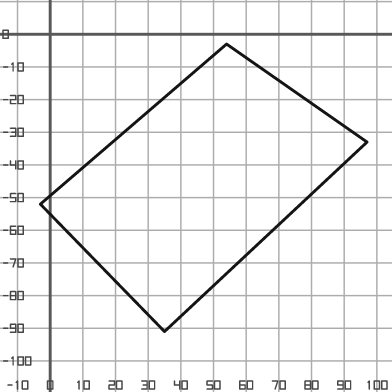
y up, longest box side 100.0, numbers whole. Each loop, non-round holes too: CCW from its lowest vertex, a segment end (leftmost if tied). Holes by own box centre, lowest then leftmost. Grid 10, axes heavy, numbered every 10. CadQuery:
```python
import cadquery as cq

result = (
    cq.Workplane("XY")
    .moveTo(35.0, -91.0)
    .lineTo(97.0, -33.0)
    .lineTo(54.0, -3.0)
    .lineTo(-3.0, -52.0)
    .close()
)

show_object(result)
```